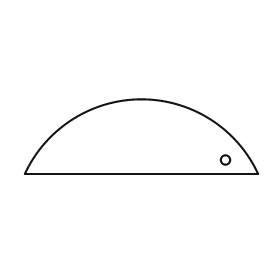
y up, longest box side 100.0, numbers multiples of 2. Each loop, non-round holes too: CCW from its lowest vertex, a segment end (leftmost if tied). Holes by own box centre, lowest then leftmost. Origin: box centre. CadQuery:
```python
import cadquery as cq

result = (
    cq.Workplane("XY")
    .moveTo(-50.0, -16.0)
    .lineTo(50.0, -16.0)
    .threePointArc((0.0, 16.0), (-50.0, -16.0))
    .close()
    .moveTo(36.0, -10.0)
    .circle(2.0)
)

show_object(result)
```